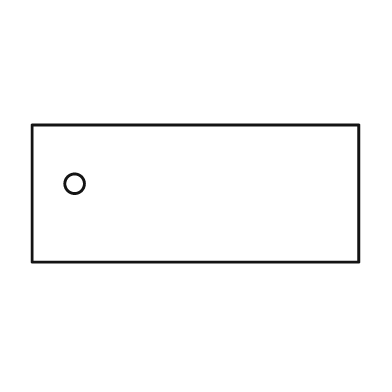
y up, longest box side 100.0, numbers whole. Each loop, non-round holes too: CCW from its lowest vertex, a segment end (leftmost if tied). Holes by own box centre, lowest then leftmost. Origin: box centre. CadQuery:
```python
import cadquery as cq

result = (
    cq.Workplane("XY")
    .moveTo(-50.0, -21.0)
    .lineTo(50.0, -21.0)
    .lineTo(50.0, 21.0)
    .lineTo(-50.0, 21.0)
    .close()
    .moveTo(-37.0, 3.0)
    .circle(3.0)
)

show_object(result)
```